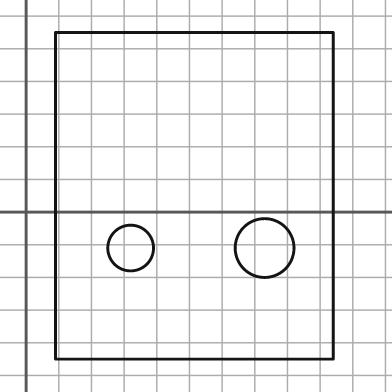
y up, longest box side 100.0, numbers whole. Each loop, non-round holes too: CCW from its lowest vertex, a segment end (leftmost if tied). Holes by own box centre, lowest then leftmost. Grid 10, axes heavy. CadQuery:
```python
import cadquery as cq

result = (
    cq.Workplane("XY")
    .moveTo(9.0, -45.0)
    .lineTo(94.0, -45.0)
    .lineTo(94.0, 55.0)
    .lineTo(9.0, 55.0)
    .close()
    .moveTo(32.0, -11.0)
    .circle(7.0)
    .moveTo(73.0, -11.0)
    .circle(9.0)
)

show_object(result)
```